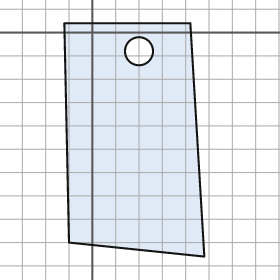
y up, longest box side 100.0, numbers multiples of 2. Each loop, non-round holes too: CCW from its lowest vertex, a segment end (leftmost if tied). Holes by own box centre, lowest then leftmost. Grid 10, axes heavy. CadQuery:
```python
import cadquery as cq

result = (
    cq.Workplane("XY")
    .moveTo(48.0, -96.0)
    .lineTo(42.0, 4.0)
    .lineTo(-12.0, 4.0)
    .lineTo(-10.0, -90.0)
    .close()
    .moveTo(20.0, -8.0)
    .circle(6.0)
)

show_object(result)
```